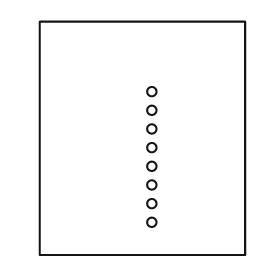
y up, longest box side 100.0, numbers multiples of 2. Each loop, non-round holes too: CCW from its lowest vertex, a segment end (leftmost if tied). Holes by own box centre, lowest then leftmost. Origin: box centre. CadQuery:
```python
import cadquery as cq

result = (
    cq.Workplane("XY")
    .moveTo(-44.0, -50.0)
    .lineTo(44.0, -50.0)
    .lineTo(44.0, 50.0)
    .lineTo(-44.0, 50.0)
    .close()
    .moveTo(4.0, -36.0)
    .circle(2.0)
    .moveTo(4.0, -28.0)
    .circle(2.0)
    .moveTo(4.0, -20.0)
    .circle(2.0)
    .moveTo(4.0, -12.0)
    .circle(2.0)
    .moveTo(4.0, -4.0)
    .circle(2.0)
    .moveTo(4.0, 4.0)
    .circle(2.0)
    .moveTo(4.0, 12.0)
    .circle(2.0)
    .moveTo(4.0, 20.0)
    .circle(2.0)
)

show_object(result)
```